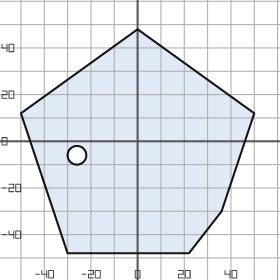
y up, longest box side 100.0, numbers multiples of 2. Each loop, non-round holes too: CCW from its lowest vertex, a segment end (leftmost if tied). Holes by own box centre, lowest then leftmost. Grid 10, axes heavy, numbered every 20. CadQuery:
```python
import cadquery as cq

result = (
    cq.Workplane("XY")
    .moveTo(-30.0, -48.0)
    .lineTo(22.0, -48.0)
    .lineTo(36.0, -30.0)
    .lineTo(50.0, 12.0)
    .lineTo(0.0, 48.0)
    .lineTo(-50.0, 12.0)
    .close()
    .moveTo(-26.0, -6.0)
    .circle(4.0)
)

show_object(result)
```